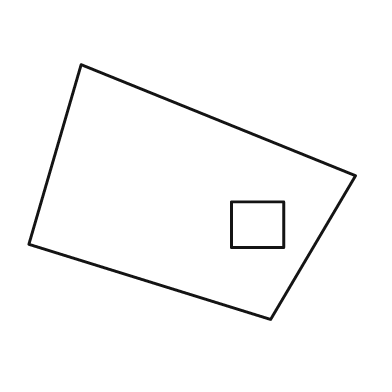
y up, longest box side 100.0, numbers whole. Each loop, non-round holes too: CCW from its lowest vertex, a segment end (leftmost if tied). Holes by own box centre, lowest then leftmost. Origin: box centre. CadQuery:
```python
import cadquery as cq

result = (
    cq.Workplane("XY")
    .moveTo(24.0, -39.0)
    .lineTo(50.0, 5.0)
    .lineTo(-34.0, 39.0)
    .lineTo(-50.0, -16.0)
    .close()
    .moveTo(12.0, -17.0)
    .lineTo(28.0, -17.0)
    .lineTo(28.0, -3.0)
    .lineTo(12.0, -3.0)
    .close()
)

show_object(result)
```